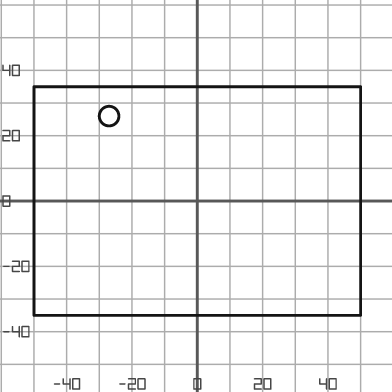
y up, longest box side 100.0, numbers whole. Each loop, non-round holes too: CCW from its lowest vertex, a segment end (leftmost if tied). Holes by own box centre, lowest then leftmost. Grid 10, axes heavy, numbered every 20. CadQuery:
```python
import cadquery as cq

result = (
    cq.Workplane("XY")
    .moveTo(-50.0, -35.0)
    .lineTo(50.0, -35.0)
    .lineTo(50.0, 35.0)
    .lineTo(-50.0, 35.0)
    .close()
    .moveTo(-27.0, 26.0)
    .circle(3.0)
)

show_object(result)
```